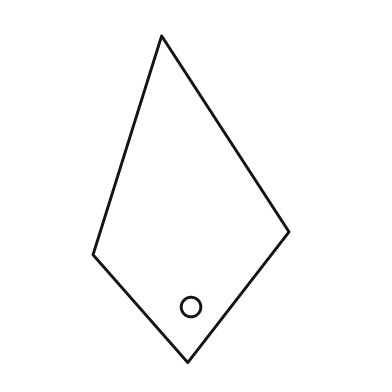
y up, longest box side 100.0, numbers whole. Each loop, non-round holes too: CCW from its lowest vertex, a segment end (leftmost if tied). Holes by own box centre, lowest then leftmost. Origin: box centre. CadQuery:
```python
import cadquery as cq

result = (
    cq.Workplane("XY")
    .moveTo(-1.0, -50.0)
    .lineTo(30.0, -10.0)
    .lineTo(-9.0, 50.0)
    .lineTo(-30.0, -17.0)
    .close()
    .moveTo(0.0, -33.0)
    .circle(3.0)
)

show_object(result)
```